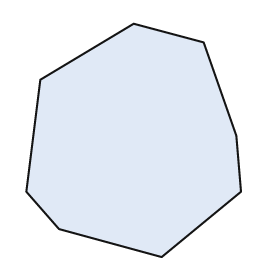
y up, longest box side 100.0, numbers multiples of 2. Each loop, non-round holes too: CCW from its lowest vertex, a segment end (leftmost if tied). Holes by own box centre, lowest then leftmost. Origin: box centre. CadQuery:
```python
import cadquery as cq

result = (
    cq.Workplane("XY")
    .moveTo(12.0, -50.0)
    .lineTo(46.0, -22.0)
    .lineTo(44.0, 2.0)
    .lineTo(30.0, 42.0)
    .lineTo(0.0, 50.0)
    .lineTo(-40.0, 26.0)
    .lineTo(-46.0, -22.0)
    .lineTo(-32.0, -38.0)
    .close()
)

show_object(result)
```